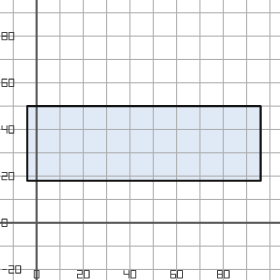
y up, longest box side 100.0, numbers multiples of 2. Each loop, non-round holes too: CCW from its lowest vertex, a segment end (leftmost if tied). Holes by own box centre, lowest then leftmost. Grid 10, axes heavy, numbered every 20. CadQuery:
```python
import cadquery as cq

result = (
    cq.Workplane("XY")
    .moveTo(-4.0, 18.0)
    .lineTo(96.0, 18.0)
    .lineTo(96.0, 50.0)
    .lineTo(-4.0, 50.0)
    .close()
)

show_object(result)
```